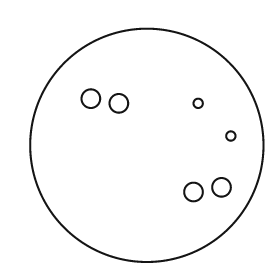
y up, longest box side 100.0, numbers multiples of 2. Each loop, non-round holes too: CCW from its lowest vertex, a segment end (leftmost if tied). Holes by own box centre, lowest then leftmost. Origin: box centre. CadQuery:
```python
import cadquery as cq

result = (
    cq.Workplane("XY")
    .moveTo(0.0, 0.0)
    .circle(50.0)
    .moveTo(20.0, -20.0)
    .circle(4.0)
    .moveTo(32.0, -18.0)
    .circle(4.0)
    .moveTo(36.0, 4.0)
    .circle(2.0)
    .moveTo(-12.0, 18.0)
    .circle(4.0)
    .moveTo(22.0, 18.0)
    .circle(2.0)
    .moveTo(-24.0, 20.0)
    .circle(4.0)
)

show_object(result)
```